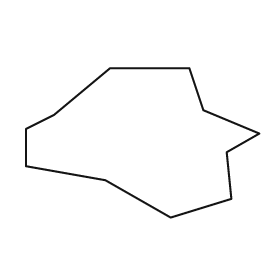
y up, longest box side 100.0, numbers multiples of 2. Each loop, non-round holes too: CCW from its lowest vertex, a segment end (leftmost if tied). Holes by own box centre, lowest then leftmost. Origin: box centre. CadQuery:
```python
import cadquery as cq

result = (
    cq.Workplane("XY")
    .moveTo(12.0, -32.0)
    .lineTo(38.0, -24.0)
    .lineTo(36.0, -4.0)
    .lineTo(50.0, 4.0)
    .lineTo(26.0, 14.0)
    .lineTo(20.0, 32.0)
    .lineTo(-14.0, 32.0)
    .lineTo(-38.0, 12.0)
    .lineTo(-50.0, 6.0)
    .lineTo(-50.0, -10.0)
    .lineTo(-16.0, -16.0)
    .close()
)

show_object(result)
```